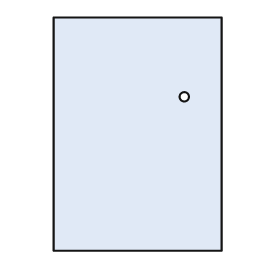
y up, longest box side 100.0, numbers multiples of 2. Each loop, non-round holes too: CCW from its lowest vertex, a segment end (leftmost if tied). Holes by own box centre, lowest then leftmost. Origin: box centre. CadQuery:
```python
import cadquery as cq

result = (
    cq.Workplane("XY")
    .moveTo(-36.0, -50.0)
    .lineTo(36.0, -50.0)
    .lineTo(36.0, 50.0)
    .lineTo(-36.0, 50.0)
    .close()
    .moveTo(20.0, 16.0)
    .circle(2.0)
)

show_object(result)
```